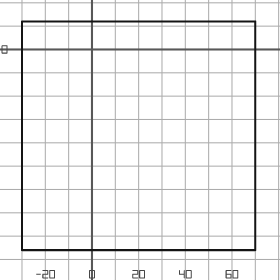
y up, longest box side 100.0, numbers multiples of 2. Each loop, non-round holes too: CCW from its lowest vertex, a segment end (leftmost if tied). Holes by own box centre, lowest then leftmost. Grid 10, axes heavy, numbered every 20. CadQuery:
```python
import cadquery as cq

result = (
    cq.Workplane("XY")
    .moveTo(-30.0, -86.0)
    .lineTo(70.0, -86.0)
    .lineTo(70.0, 12.0)
    .lineTo(-30.0, 12.0)
    .close()
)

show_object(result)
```